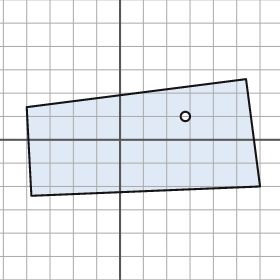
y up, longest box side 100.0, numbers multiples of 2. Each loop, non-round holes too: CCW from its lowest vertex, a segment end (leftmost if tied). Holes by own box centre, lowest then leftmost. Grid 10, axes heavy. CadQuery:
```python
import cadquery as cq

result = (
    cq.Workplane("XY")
    .moveTo(-38.0, -24.0)
    .lineTo(60.0, -20.0)
    .lineTo(54.0, 26.0)
    .lineTo(-40.0, 14.0)
    .close()
    .moveTo(28.0, 10.0)
    .circle(2.0)
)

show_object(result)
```